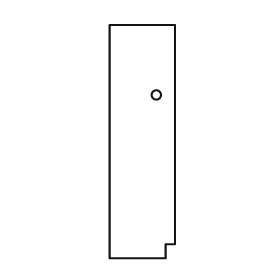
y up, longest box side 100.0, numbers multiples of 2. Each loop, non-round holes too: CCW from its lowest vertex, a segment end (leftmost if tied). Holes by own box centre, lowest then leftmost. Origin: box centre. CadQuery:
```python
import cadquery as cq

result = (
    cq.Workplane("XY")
    .moveTo(-14.0, -50.0)
    .lineTo(10.0, -50.0)
    .lineTo(10.0, -44.0)
    .lineTo(14.0, -44.0)
    .lineTo(14.0, 50.0)
    .lineTo(-14.0, 50.0)
    .close()
    .moveTo(6.0, 20.0)
    .circle(2.0)
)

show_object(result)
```